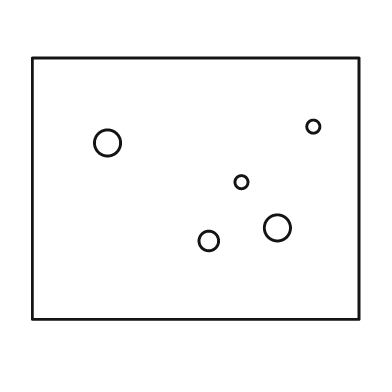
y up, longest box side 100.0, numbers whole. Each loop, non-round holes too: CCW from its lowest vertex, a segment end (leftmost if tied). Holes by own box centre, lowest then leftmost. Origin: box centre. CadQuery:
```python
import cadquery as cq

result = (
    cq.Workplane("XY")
    .moveTo(-50.0, -40.0)
    .lineTo(50.0, -40.0)
    .lineTo(50.0, 40.0)
    .lineTo(-50.0, 40.0)
    .close()
    .moveTo(4.0, -16.0)
    .circle(3.0)
    .moveTo(25.0, -12.0)
    .circle(4.0)
    .moveTo(14.0, 2.0)
    .circle(2.0)
    .moveTo(-27.0, 14.0)
    .circle(4.0)
    .moveTo(36.0, 19.0)
    .circle(2.0)
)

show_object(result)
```